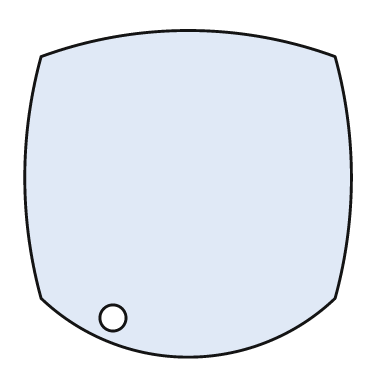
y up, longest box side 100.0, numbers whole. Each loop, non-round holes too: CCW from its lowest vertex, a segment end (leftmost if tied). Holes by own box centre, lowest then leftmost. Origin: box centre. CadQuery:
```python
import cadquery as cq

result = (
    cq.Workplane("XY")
    .moveTo(-45.0, -32.0)
    .threePointArc((0.0, -50.0), (45.0, -32.0))
    .threePointArc((50.0, 5.0), (45.0, 42.0))
    .threePointArc((0.0, 50.0), (-45.0, 42.0))
    .threePointArc((-50.0, 5.0), (-45.0, -32.0))
    .close()
    .moveTo(-23.0, -38.0)
    .circle(4.0)
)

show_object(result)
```